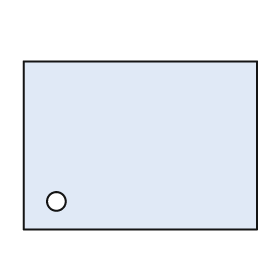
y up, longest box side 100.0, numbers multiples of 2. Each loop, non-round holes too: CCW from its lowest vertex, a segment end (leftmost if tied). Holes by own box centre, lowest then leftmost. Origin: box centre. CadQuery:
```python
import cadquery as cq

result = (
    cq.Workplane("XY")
    .moveTo(-50.0, -36.0)
    .lineTo(50.0, -36.0)
    .lineTo(50.0, 36.0)
    .lineTo(-50.0, 36.0)
    .close()
    .moveTo(-36.0, -24.0)
    .circle(4.0)
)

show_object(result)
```